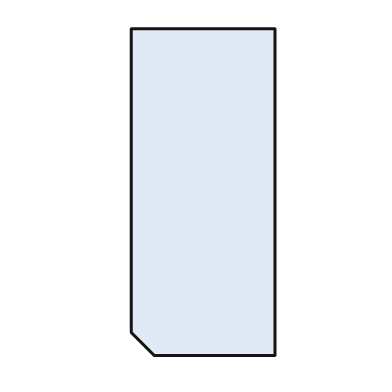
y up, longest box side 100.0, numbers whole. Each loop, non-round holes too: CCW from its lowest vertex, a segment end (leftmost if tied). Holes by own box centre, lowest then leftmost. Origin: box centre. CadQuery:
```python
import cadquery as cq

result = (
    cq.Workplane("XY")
    .moveTo(-15.0, -50.0)
    .lineTo(22.0, -50.0)
    .lineTo(22.0, 50.0)
    .lineTo(-22.0, 50.0)
    .lineTo(-22.0, -43.0)
    .close()
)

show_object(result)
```